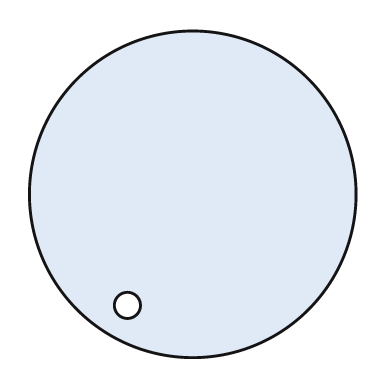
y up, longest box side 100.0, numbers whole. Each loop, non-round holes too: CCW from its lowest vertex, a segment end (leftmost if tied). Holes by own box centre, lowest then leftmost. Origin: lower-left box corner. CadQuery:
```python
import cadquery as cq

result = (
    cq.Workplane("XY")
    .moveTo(50.0, 50.0)
    .circle(50.0)
    .moveTo(30.0, 16.0)
    .circle(4.0)
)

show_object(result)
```